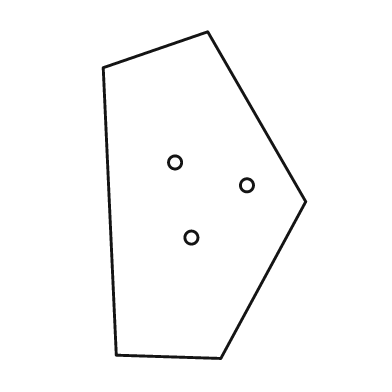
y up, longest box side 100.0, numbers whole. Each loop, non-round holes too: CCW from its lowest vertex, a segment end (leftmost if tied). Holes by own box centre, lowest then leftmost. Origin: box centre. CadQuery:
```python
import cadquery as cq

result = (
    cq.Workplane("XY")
    .moveTo(5.0, -50.0)
    .lineTo(31.0, -2.0)
    .lineTo(1.0, 50.0)
    .lineTo(-31.0, 39.0)
    .lineTo(-27.0, -49.0)
    .close()
    .moveTo(-4.0, -13.0)
    .circle(2.0)
    .moveTo(13.0, 3.0)
    .circle(2.0)
    .moveTo(-9.0, 10.0)
    .circle(2.0)
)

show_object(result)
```